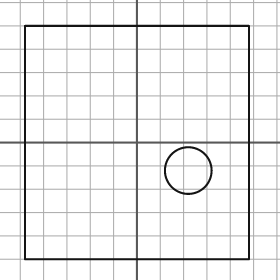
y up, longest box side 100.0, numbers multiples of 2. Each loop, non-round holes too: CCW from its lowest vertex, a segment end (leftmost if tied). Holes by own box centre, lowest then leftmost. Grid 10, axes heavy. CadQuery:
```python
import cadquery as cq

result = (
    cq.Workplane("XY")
    .moveTo(-48.0, -50.0)
    .lineTo(48.0, -50.0)
    .lineTo(48.0, 50.0)
    .lineTo(-48.0, 50.0)
    .close()
    .moveTo(22.0, -12.0)
    .circle(10.0)
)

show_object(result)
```